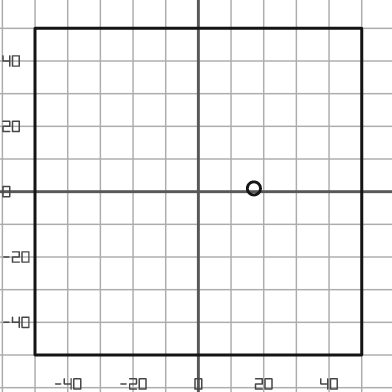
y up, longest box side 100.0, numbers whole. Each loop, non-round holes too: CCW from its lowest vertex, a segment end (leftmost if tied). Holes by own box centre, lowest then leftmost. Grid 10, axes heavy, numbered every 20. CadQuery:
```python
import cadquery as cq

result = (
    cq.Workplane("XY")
    .moveTo(-50.0, -50.0)
    .lineTo(50.0, -50.0)
    .lineTo(50.0, 50.0)
    .lineTo(-50.0, 50.0)
    .close()
    .moveTo(17.0, 1.0)
    .circle(2.0)
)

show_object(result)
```